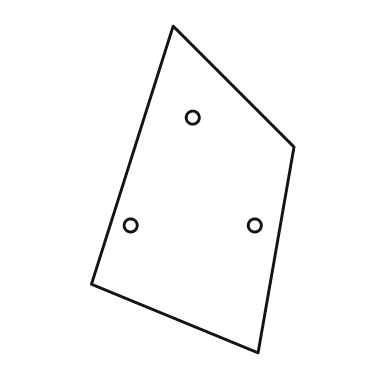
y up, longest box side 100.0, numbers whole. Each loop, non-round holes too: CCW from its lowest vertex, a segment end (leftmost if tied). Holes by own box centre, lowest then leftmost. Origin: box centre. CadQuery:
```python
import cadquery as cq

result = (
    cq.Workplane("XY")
    .moveTo(20.0, -50.0)
    .lineTo(31.0, 13.0)
    .lineTo(-6.0, 50.0)
    .lineTo(-31.0, -29.0)
    .close()
    .moveTo(-19.0, -11.0)
    .circle(2.0)
    .moveTo(19.0, -11.0)
    .circle(2.0)
    .moveTo(0.0, 22.0)
    .circle(2.0)
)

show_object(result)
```